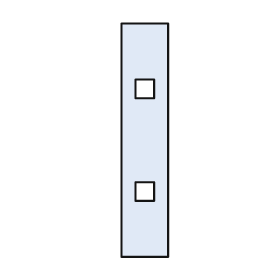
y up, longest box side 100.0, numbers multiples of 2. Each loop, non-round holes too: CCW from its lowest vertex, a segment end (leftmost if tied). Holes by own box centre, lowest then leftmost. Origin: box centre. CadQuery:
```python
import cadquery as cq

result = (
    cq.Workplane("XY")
    .moveTo(-10.0, -50.0)
    .lineTo(10.0, -50.0)
    .lineTo(10.0, 50.0)
    .lineTo(-10.0, 50.0)
    .close()
    .moveTo(-4.0, -26.0)
    .lineTo(4.0, -26.0)
    .lineTo(4.0, -18.0)
    .lineTo(-4.0, -18.0)
    .close()
    .moveTo(-4.0, 18.0)
    .lineTo(4.0, 18.0)
    .lineTo(4.0, 26.0)
    .lineTo(-4.0, 26.0)
    .close()
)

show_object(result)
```